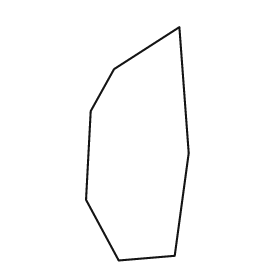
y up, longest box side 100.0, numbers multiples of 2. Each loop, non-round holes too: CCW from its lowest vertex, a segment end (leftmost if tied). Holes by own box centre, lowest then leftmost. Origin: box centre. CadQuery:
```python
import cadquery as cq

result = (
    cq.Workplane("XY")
    .moveTo(-8.0, -50.0)
    .lineTo(16.0, -48.0)
    .lineTo(22.0, -4.0)
    .lineTo(18.0, 50.0)
    .lineTo(-10.0, 32.0)
    .lineTo(-20.0, 14.0)
    .lineTo(-22.0, -24.0)
    .close()
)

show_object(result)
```